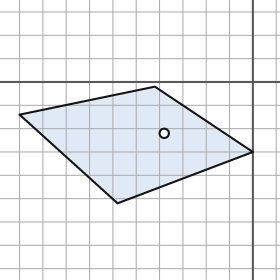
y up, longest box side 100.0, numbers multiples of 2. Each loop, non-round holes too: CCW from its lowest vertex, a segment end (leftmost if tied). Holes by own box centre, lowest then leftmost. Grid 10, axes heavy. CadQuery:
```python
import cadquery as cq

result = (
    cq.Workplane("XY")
    .moveTo(-58.0, -52.0)
    .lineTo(0.0, -30.0)
    .lineTo(-42.0, -2.0)
    .lineTo(-100.0, -14.0)
    .close()
    .moveTo(-38.0, -22.0)
    .circle(2.0)
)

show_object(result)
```